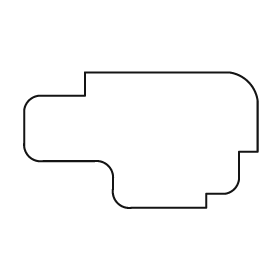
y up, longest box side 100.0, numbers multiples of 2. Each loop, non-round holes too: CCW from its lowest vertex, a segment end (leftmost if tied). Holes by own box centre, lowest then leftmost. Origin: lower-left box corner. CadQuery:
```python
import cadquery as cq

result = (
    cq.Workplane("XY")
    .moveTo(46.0, 0.0)
    .lineTo(78.0, 0.0)
    .lineTo(78.0, 6.0)
    .lineTo(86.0, 6.0)
    .threePointArc((90.0, 8.0), (92.0, 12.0))
    .lineTo(92.0, 24.0)
    .lineTo(100.0, 24.0)
    .lineTo(100.0, 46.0)
    .threePointArc((96.0, 54.0), (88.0, 58.0))
    .lineTo(26.0, 58.0)
    .lineTo(26.0, 48.0)
    .lineTo(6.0, 48.0)
    .threePointArc((2.0, 46.0), (0.0, 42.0))
    .lineTo(0.0, 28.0)
    .threePointArc((2.0, 22.0), (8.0, 20.0))
    .lineTo(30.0, 20.0)
    .threePointArc((36.0, 18.0), (38.0, 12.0))
    .lineTo(38.0, 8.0)
    .threePointArc((40.0, 2.0), (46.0, 0.0))
    .close()
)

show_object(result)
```